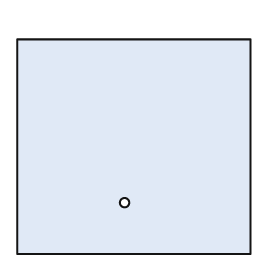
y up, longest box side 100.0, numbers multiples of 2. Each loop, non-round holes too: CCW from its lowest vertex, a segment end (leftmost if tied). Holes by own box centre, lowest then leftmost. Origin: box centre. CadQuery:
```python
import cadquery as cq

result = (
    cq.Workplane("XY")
    .moveTo(-50.0, -46.0)
    .lineTo(50.0, -46.0)
    .lineTo(50.0, 46.0)
    .lineTo(-50.0, 46.0)
    .close()
    .moveTo(-4.0, -24.0)
    .circle(2.0)
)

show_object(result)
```